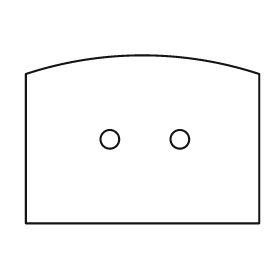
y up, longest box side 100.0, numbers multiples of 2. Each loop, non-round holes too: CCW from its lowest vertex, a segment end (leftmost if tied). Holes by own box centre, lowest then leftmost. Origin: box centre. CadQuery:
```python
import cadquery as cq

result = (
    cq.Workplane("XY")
    .moveTo(-50.0, -36.0)
    .lineTo(50.0, -36.0)
    .lineTo(50.0, 28.0)
    .threePointArc((0.0, 36.0), (-50.0, 28.0))
    .close()
    .moveTo(-14.0, 0.0)
    .circle(4.0)
    .moveTo(16.0, 0.0)
    .circle(4.0)
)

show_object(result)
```